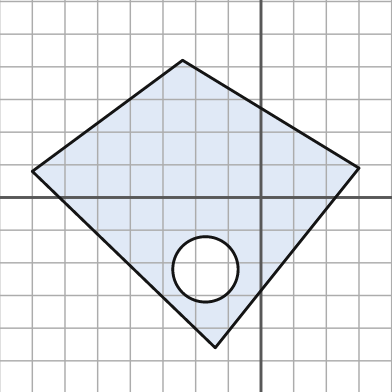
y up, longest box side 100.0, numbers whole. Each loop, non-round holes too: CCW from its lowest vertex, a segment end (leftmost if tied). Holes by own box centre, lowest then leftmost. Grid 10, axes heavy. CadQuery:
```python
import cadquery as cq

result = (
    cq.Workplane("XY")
    .moveTo(-14.0, -46.0)
    .lineTo(30.0, 9.0)
    .lineTo(-24.0, 42.0)
    .lineTo(-70.0, 8.0)
    .close()
    .moveTo(-17.0, -22.0)
    .circle(10.0)
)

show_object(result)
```